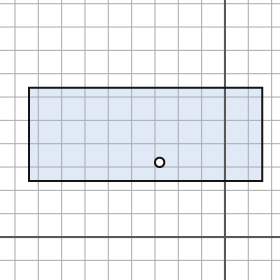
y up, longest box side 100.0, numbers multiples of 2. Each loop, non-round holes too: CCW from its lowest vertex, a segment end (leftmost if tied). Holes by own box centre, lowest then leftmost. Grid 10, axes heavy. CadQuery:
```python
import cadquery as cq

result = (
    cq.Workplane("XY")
    .moveTo(-84.0, 24.0)
    .lineTo(16.0, 24.0)
    .lineTo(16.0, 64.0)
    .lineTo(-84.0, 64.0)
    .close()
    .moveTo(-28.0, 32.0)
    .circle(2.0)
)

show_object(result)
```